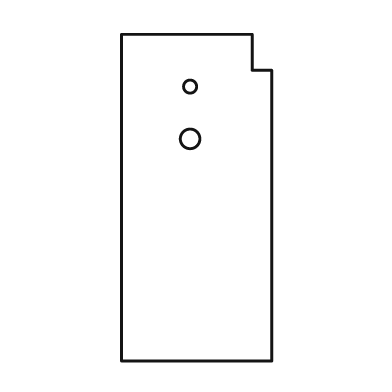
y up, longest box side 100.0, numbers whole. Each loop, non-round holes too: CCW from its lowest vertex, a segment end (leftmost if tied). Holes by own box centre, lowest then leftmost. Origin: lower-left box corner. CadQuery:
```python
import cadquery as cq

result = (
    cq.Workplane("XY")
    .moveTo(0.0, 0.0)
    .lineTo(46.0, 0.0)
    .lineTo(46.0, 89.0)
    .lineTo(40.0, 89.0)
    .lineTo(40.0, 100.0)
    .lineTo(0.0, 100.0)
    .close()
    .moveTo(21.0, 68.0)
    .circle(3.0)
    .moveTo(21.0, 84.0)
    .circle(2.0)
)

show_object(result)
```